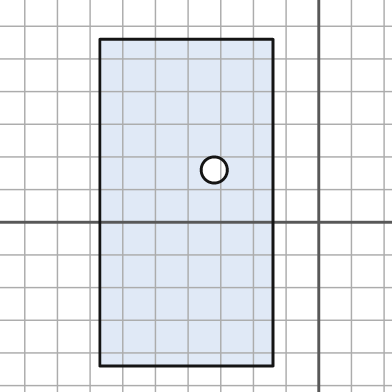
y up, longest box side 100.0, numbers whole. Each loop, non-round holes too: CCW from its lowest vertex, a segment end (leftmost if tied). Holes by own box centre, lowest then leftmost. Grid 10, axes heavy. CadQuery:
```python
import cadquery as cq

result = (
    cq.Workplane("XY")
    .moveTo(-67.0, -44.0)
    .lineTo(-14.0, -44.0)
    .lineTo(-14.0, 56.0)
    .lineTo(-67.0, 56.0)
    .close()
    .moveTo(-32.0, 16.0)
    .circle(4.0)
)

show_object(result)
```